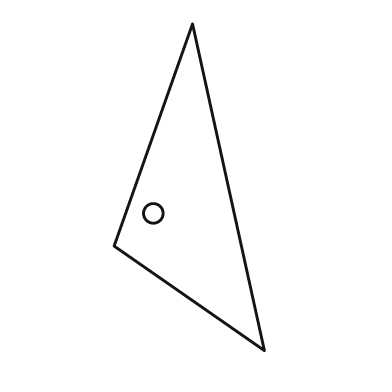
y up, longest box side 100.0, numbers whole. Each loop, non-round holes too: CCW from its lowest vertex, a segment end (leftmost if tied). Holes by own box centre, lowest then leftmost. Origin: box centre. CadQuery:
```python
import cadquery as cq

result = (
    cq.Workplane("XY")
    .moveTo(23.0, -50.0)
    .lineTo(1.0, 50.0)
    .lineTo(-23.0, -18.0)
    .close()
    .moveTo(-11.0, -8.0)
    .circle(3.0)
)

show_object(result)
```